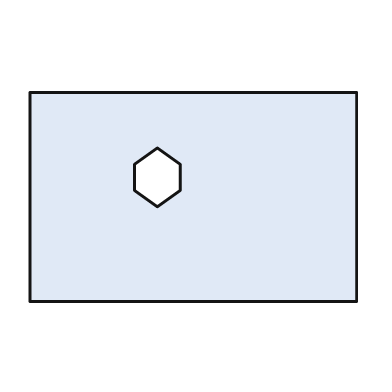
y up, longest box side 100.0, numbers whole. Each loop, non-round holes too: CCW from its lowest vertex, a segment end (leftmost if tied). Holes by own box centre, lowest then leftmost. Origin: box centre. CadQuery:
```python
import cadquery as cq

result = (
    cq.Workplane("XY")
    .moveTo(-50.0, -32.0)
    .lineTo(50.0, -32.0)
    .lineTo(50.0, 32.0)
    .lineTo(-50.0, 32.0)
    .close()
    .moveTo(-11.0, -3.0)
    .lineTo(-4.0, 2.0)
    .lineTo(-4.0, 10.0)
    .lineTo(-11.0, 15.0)
    .lineTo(-18.0, 10.0)
    .lineTo(-18.0, 2.0)
    .close()
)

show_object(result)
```